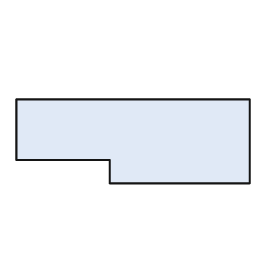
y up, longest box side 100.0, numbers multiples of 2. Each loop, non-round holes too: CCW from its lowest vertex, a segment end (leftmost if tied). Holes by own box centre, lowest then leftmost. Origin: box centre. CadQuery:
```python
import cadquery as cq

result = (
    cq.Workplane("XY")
    .moveTo(-10.0, -18.0)
    .lineTo(50.0, -18.0)
    .lineTo(50.0, 18.0)
    .lineTo(-50.0, 18.0)
    .lineTo(-50.0, -8.0)
    .lineTo(-10.0, -8.0)
    .close()
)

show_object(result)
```